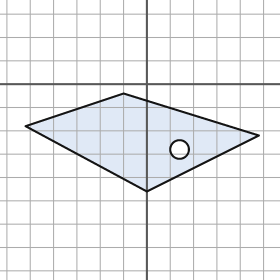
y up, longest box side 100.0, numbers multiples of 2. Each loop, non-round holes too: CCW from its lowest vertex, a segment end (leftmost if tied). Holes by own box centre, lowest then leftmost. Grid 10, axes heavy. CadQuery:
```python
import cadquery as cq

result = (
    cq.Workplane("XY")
    .moveTo(0.0, -46.0)
    .lineTo(48.0, -22.0)
    .lineTo(-10.0, -4.0)
    .lineTo(-52.0, -18.0)
    .close()
    .moveTo(14.0, -28.0)
    .circle(4.0)
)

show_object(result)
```